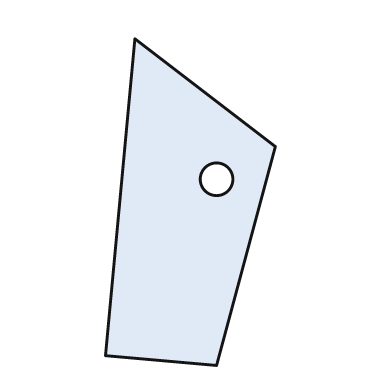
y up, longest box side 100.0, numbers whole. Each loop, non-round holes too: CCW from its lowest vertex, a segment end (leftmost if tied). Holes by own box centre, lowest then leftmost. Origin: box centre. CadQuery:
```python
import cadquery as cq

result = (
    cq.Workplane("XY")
    .moveTo(8.0, -50.0)
    .lineTo(26.0, 17.0)
    .lineTo(-17.0, 50.0)
    .lineTo(-26.0, -47.0)
    .close()
    .moveTo(8.0, 7.0)
    .circle(5.0)
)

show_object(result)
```